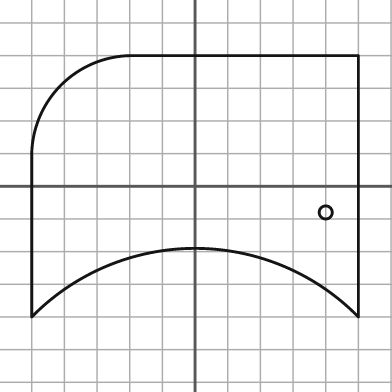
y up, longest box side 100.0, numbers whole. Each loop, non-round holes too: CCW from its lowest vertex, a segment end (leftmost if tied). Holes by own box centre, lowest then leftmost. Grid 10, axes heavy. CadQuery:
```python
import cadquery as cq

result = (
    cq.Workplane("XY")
    .moveTo(-50.0, -40.0)
    .threePointArc((0.0, -19.0), (50.0, -40.0))
    .lineTo(50.0, 40.0)
    .lineTo(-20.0, 40.0)
    .threePointArc((-41.0, 31.0), (-50.0, 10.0))
    .close()
    .moveTo(40.0, -8.0)
    .circle(2.0)
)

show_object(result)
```